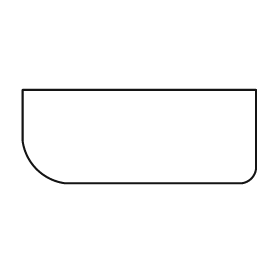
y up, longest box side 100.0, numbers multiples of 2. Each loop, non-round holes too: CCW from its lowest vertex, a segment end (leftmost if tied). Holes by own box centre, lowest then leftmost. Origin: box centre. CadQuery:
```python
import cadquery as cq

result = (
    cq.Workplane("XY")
    .moveTo(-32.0, -20.0)
    .lineTo(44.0, -20.0)
    .threePointArc((48.0, -18.0), (50.0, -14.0))
    .lineTo(50.0, 20.0)
    .lineTo(-50.0, 20.0)
    .lineTo(-50.0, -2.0)
    .threePointArc((-44.0, -14.0), (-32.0, -20.0))
    .close()
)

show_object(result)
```